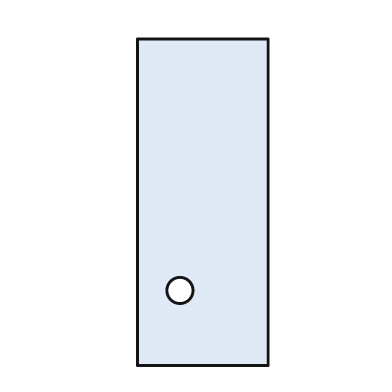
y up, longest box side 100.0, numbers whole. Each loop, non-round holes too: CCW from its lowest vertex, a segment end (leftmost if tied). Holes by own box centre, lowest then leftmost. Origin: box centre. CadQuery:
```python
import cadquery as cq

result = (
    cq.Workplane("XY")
    .moveTo(-20.0, -50.0)
    .lineTo(20.0, -50.0)
    .lineTo(20.0, 50.0)
    .lineTo(-20.0, 50.0)
    .close()
    .moveTo(-7.0, -27.0)
    .circle(4.0)
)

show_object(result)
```